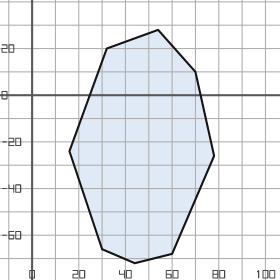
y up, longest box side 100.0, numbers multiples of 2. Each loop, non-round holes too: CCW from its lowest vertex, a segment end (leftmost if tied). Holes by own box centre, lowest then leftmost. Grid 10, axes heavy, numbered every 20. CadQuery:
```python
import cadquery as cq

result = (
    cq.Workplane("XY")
    .moveTo(44.0, -72.0)
    .lineTo(60.0, -68.0)
    .lineTo(78.0, -26.0)
    .lineTo(70.0, 10.0)
    .lineTo(54.0, 28.0)
    .lineTo(32.0, 20.0)
    .lineTo(16.0, -24.0)
    .lineTo(30.0, -66.0)
    .close()
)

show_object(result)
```